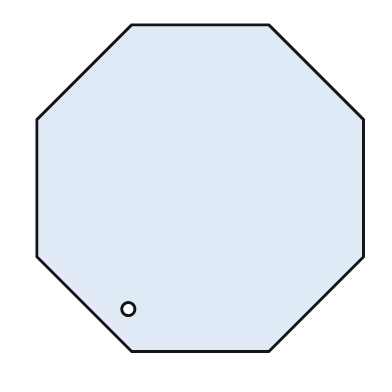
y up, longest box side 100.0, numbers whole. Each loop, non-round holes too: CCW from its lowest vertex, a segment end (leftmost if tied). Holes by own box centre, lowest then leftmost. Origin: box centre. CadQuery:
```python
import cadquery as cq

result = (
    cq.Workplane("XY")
    .moveTo(-21.0, -50.0)
    .lineTo(21.0, -50.0)
    .lineTo(50.0, -21.0)
    .lineTo(50.0, 21.0)
    .lineTo(21.0, 50.0)
    .lineTo(-21.0, 50.0)
    .lineTo(-50.0, 21.0)
    .lineTo(-50.0, -21.0)
    .close()
    .moveTo(-22.0, -37.0)
    .circle(2.0)
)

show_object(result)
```